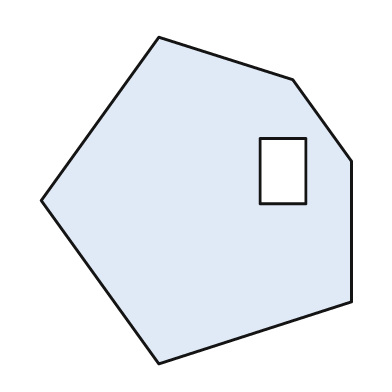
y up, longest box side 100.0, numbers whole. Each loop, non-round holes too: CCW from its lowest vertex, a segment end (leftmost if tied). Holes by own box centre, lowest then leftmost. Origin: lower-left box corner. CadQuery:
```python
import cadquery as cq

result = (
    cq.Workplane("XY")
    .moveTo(36.0, 0.0)
    .lineTo(95.0, 19.0)
    .lineTo(95.0, 62.0)
    .lineTo(77.0, 87.0)
    .lineTo(36.0, 100.0)
    .lineTo(0.0, 50.0)
    .close()
    .moveTo(67.0, 49.0)
    .lineTo(81.0, 49.0)
    .lineTo(81.0, 69.0)
    .lineTo(67.0, 69.0)
    .close()
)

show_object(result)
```